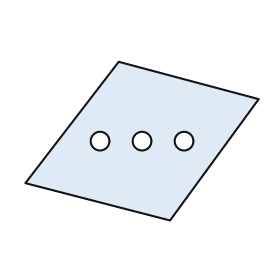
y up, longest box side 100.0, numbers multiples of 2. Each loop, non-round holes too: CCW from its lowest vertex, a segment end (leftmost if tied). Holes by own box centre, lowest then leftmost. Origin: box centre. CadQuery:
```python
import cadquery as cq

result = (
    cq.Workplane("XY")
    .moveTo(12.0, -34.0)
    .lineTo(50.0, 18.0)
    .lineTo(-10.0, 34.0)
    .lineTo(-50.0, -18.0)
    .close()
    .moveTo(-18.0, 0.0)
    .circle(4.0)
    .moveTo(0.0, 0.0)
    .circle(4.0)
    .moveTo(18.0, 0.0)
    .circle(4.0)
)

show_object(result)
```